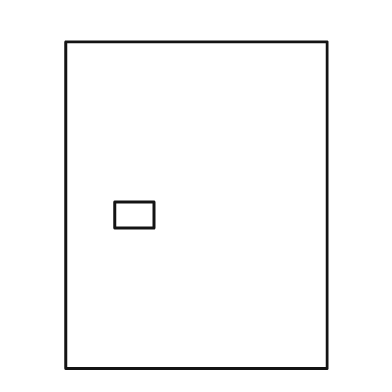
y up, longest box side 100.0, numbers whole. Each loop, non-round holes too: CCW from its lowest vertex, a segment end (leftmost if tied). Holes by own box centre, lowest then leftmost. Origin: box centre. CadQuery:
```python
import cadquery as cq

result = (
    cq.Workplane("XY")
    .moveTo(-40.0, -50.0)
    .lineTo(40.0, -50.0)
    .lineTo(40.0, 50.0)
    .lineTo(-40.0, 50.0)
    .close()
    .moveTo(-25.0, -7.0)
    .lineTo(-13.0, -7.0)
    .lineTo(-13.0, 1.0)
    .lineTo(-25.0, 1.0)
    .close()
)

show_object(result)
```